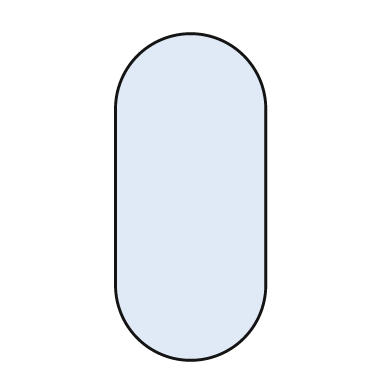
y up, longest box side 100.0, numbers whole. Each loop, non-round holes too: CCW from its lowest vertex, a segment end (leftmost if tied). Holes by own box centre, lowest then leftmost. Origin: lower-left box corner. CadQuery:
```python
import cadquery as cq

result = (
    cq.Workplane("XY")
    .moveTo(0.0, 23.0)
    .threePointArc((23.0, 0.0), (46.0, 23.0))
    .lineTo(46.0, 77.0)
    .threePointArc((23.0, 100.0), (0.0, 77.0))
    .close()
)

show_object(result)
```